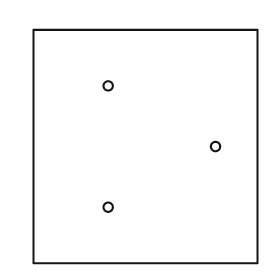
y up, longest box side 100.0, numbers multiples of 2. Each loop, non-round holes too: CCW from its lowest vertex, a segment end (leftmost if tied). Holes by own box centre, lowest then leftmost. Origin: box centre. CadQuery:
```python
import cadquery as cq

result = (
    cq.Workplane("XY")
    .moveTo(-48.0, -50.0)
    .lineTo(48.0, -50.0)
    .lineTo(48.0, 50.0)
    .lineTo(-48.0, 50.0)
    .close()
    .moveTo(-16.0, -26.0)
    .circle(2.0)
    .moveTo(30.0, 0.0)
    .circle(2.0)
    .moveTo(-16.0, 26.0)
    .circle(2.0)
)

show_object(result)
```